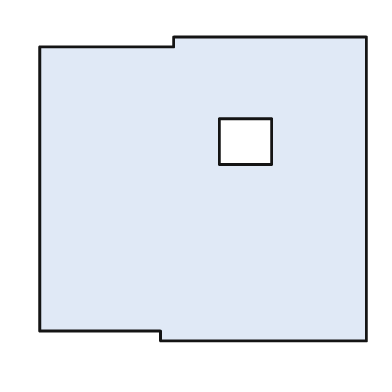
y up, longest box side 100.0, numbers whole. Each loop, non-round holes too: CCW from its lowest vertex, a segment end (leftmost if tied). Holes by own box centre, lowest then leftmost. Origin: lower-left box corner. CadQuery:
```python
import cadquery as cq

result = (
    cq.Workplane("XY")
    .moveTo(37.0, 0.0)
    .lineTo(100.0, 0.0)
    .lineTo(100.0, 93.0)
    .lineTo(41.0, 93.0)
    .lineTo(41.0, 90.0)
    .lineTo(0.0, 90.0)
    .lineTo(0.0, 3.0)
    .lineTo(37.0, 3.0)
    .close()
    .moveTo(55.0, 54.0)
    .lineTo(71.0, 54.0)
    .lineTo(71.0, 68.0)
    .lineTo(55.0, 68.0)
    .close()
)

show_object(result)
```